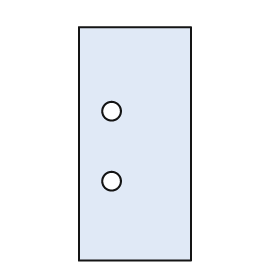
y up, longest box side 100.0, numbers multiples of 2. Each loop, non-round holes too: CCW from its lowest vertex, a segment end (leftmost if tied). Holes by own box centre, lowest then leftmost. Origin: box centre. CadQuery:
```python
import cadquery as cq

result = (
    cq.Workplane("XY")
    .moveTo(-24.0, -50.0)
    .lineTo(24.0, -50.0)
    .lineTo(24.0, 50.0)
    .lineTo(-24.0, 50.0)
    .close()
    .moveTo(-10.0, -16.0)
    .circle(4.0)
    .moveTo(-10.0, 14.0)
    .circle(4.0)
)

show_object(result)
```